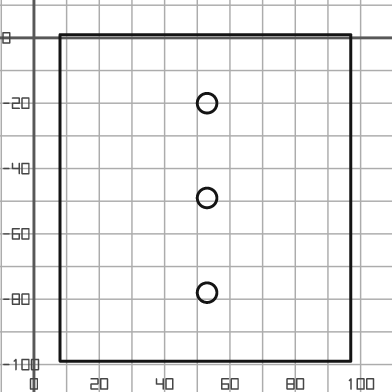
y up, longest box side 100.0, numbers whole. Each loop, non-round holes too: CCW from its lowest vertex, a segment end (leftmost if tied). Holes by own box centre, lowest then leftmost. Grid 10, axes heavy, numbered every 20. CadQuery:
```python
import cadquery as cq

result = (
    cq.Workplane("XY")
    .moveTo(8.0, -99.0)
    .lineTo(97.0, -99.0)
    .lineTo(97.0, 1.0)
    .lineTo(8.0, 1.0)
    .close()
    .moveTo(53.0, -78.0)
    .circle(3.0)
    .moveTo(53.0, -49.0)
    .circle(3.0)
    .moveTo(53.0, -20.0)
    .circle(3.0)
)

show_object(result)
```